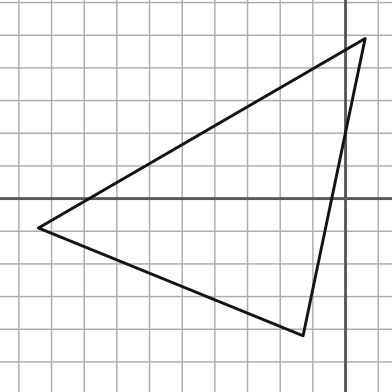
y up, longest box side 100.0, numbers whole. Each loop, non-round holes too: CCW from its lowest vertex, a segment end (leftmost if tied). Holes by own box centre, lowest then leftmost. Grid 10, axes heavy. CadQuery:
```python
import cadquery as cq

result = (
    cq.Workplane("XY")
    .moveTo(-13.0, -42.0)
    .lineTo(6.0, 49.0)
    .lineTo(-94.0, -9.0)
    .close()
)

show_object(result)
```